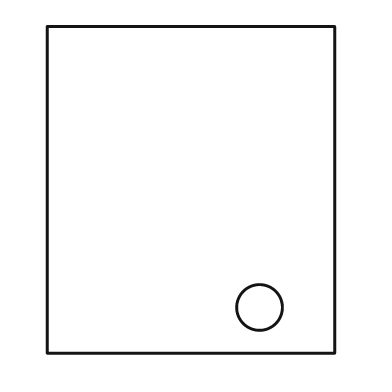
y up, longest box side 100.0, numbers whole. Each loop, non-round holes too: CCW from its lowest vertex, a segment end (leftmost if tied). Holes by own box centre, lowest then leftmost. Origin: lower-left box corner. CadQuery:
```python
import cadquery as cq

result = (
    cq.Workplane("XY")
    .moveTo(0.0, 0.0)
    .lineTo(88.0, 0.0)
    .lineTo(88.0, 100.0)
    .lineTo(0.0, 100.0)
    .close()
    .moveTo(65.0, 14.0)
    .circle(7.0)
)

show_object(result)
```